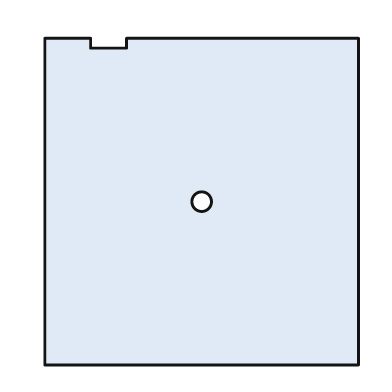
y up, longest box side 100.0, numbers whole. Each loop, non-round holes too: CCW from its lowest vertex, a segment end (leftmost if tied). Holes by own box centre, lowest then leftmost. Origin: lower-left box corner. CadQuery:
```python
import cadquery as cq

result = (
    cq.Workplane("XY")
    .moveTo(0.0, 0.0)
    .lineTo(96.0, 0.0)
    .lineTo(96.0, 100.0)
    .lineTo(25.0, 100.0)
    .lineTo(25.0, 97.0)
    .lineTo(14.0, 97.0)
    .lineTo(14.0, 100.0)
    .lineTo(0.0, 100.0)
    .close()
    .moveTo(48.0, 50.0)
    .circle(3.0)
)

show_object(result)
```